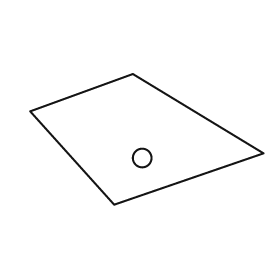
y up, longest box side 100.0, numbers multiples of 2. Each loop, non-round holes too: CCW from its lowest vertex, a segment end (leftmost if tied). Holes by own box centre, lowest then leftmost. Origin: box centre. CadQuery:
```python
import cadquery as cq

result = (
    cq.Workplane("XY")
    .moveTo(-14.0, -28.0)
    .lineTo(50.0, -6.0)
    .lineTo(-6.0, 28.0)
    .lineTo(-50.0, 12.0)
    .close()
    .moveTo(-2.0, -8.0)
    .circle(4.0)
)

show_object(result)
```